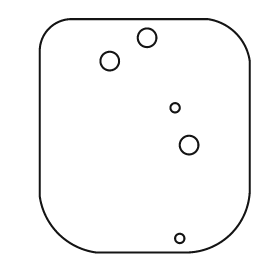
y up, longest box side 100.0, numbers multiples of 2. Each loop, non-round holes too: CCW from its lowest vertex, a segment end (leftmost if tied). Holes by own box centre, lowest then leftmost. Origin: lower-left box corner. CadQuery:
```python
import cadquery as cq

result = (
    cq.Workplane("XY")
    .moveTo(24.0, 0.0)
    .lineTo(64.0, 0.0)
    .threePointArc((82.0, 8.0), (90.0, 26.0))
    .lineTo(90.0, 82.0)
    .threePointArc((84.0, 94.0), (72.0, 100.0))
    .lineTo(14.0, 100.0)
    .threePointArc((4.0, 96.0), (0.0, 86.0))
    .lineTo(0.0, 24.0)
    .threePointArc((8.0, 8.0), (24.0, 0.0))
    .close()
    .moveTo(60.0, 6.0)
    .circle(2.0)
    .moveTo(64.0, 46.0)
    .circle(4.0)
    .moveTo(58.0, 62.0)
    .circle(2.0)
    .moveTo(30.0, 82.0)
    .circle(4.0)
    .moveTo(46.0, 92.0)
    .circle(4.0)
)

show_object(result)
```